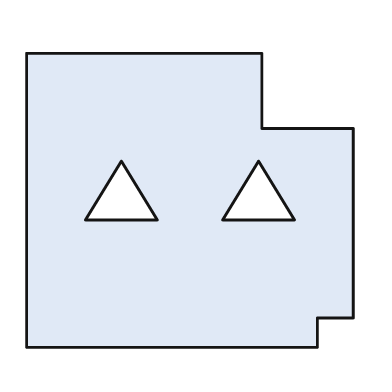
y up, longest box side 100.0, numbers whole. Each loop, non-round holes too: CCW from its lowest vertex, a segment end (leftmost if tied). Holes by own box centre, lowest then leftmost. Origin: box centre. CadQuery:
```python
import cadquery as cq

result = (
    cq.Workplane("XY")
    .moveTo(-50.0, -45.0)
    .lineTo(39.0, -45.0)
    .lineTo(39.0, -36.0)
    .lineTo(50.0, -36.0)
    .lineTo(50.0, 22.0)
    .lineTo(22.0, 22.0)
    .lineTo(22.0, 45.0)
    .lineTo(-50.0, 45.0)
    .close()
    .moveTo(-32.0, -6.0)
    .lineTo(-10.0, -6.0)
    .lineTo(-21.0, 12.0)
    .close()
    .moveTo(10.0, -6.0)
    .lineTo(32.0, -6.0)
    .lineTo(21.0, 12.0)
    .close()
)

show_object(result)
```